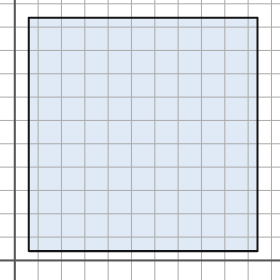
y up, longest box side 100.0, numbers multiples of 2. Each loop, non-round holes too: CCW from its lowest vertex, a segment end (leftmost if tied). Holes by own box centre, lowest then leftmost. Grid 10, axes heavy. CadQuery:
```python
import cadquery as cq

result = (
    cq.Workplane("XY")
    .moveTo(6.0, 4.0)
    .lineTo(104.0, 4.0)
    .lineTo(104.0, 104.0)
    .lineTo(6.0, 104.0)
    .close()
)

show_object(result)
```